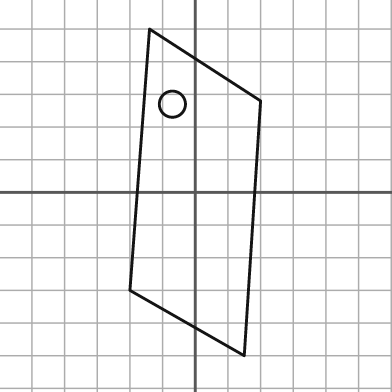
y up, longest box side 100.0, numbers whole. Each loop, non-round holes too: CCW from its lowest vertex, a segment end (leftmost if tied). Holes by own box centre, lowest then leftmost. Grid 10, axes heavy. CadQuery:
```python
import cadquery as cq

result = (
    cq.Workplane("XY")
    .moveTo(15.0, -50.0)
    .lineTo(20.0, 28.0)
    .lineTo(-14.0, 50.0)
    .lineTo(-20.0, -30.0)
    .close()
    .moveTo(-7.0, 27.0)
    .circle(4.0)
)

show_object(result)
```